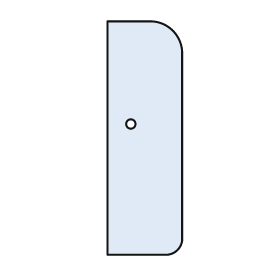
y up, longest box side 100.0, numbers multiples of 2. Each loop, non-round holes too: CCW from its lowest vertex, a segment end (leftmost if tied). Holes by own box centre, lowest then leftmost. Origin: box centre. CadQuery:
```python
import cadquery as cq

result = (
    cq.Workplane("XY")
    .moveTo(-16.0, -50.0)
    .lineTo(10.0, -50.0)
    .threePointArc((14.0, -48.0), (16.0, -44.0))
    .lineTo(16.0, 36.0)
    .threePointArc((12.0, 46.0), (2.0, 50.0))
    .lineTo(-16.0, 50.0)
    .close()
    .moveTo(-6.0, 6.0)
    .circle(2.0)
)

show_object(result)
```